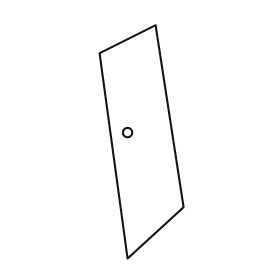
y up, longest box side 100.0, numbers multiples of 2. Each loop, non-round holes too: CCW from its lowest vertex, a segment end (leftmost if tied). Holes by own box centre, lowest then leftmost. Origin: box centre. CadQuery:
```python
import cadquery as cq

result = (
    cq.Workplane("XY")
    .moveTo(-6.0, -50.0)
    .lineTo(18.0, -28.0)
    .lineTo(6.0, 50.0)
    .lineTo(-18.0, 38.0)
    .close()
    .moveTo(-6.0, 4.0)
    .circle(2.0)
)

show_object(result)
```